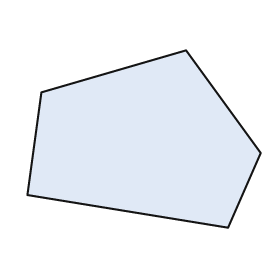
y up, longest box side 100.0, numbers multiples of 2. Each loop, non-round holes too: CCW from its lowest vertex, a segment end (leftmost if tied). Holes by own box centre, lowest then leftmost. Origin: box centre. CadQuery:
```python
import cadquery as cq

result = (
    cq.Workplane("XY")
    .moveTo(36.0, -38.0)
    .lineTo(50.0, -6.0)
    .lineTo(18.0, 38.0)
    .lineTo(-44.0, 20.0)
    .lineTo(-50.0, -24.0)
    .close()
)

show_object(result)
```